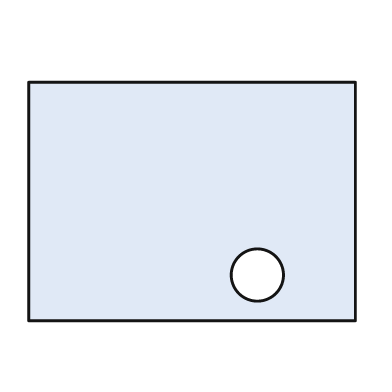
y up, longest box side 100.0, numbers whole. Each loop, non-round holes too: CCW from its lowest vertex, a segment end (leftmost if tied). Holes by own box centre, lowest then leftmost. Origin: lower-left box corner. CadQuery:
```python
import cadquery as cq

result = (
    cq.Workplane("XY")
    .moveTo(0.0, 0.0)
    .lineTo(100.0, 0.0)
    .lineTo(100.0, 73.0)
    .lineTo(0.0, 73.0)
    .close()
    .moveTo(70.0, 14.0)
    .circle(8.0)
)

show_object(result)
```